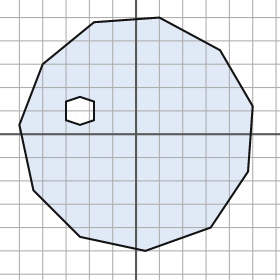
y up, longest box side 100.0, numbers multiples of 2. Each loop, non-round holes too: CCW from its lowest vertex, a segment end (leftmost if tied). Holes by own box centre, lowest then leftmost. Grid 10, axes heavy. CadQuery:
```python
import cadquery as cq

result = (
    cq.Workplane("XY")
    .moveTo(4.0, -50.0)
    .lineTo(32.0, -40.0)
    .lineTo(48.0, -16.0)
    .lineTo(50.0, 12.0)
    .lineTo(36.0, 36.0)
    .lineTo(10.0, 50.0)
    .lineTo(-18.0, 48.0)
    .lineTo(-40.0, 30.0)
    .lineTo(-50.0, 4.0)
    .lineTo(-44.0, -24.0)
    .lineTo(-24.0, -44.0)
    .close()
    .moveTo(-24.0, 4.0)
    .lineTo(-18.0, 6.0)
    .lineTo(-18.0, 14.0)
    .lineTo(-24.0, 16.0)
    .lineTo(-30.0, 14.0)
    .lineTo(-30.0, 6.0)
    .close()
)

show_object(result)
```